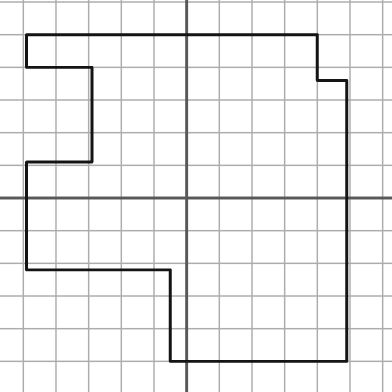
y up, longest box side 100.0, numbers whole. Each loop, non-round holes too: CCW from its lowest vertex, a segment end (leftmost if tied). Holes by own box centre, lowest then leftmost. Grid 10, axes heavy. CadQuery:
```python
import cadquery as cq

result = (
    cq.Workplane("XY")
    .moveTo(-5.0, -50.0)
    .lineTo(49.0, -50.0)
    .lineTo(49.0, 36.0)
    .lineTo(40.0, 36.0)
    .lineTo(40.0, 50.0)
    .lineTo(-49.0, 50.0)
    .lineTo(-49.0, 40.0)
    .lineTo(-29.0, 40.0)
    .lineTo(-29.0, 11.0)
    .lineTo(-49.0, 11.0)
    .lineTo(-49.0, -22.0)
    .lineTo(-5.0, -22.0)
    .close()
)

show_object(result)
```